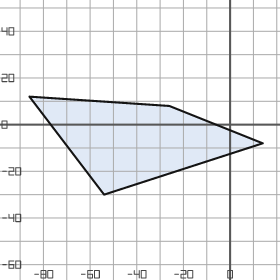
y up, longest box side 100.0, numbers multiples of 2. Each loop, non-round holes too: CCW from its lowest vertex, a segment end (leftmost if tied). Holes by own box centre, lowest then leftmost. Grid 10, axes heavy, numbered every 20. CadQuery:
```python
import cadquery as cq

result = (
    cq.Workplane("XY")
    .moveTo(-54.0, -30.0)
    .lineTo(14.0, -8.0)
    .lineTo(-26.0, 8.0)
    .lineTo(-86.0, 12.0)
    .close()
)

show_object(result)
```